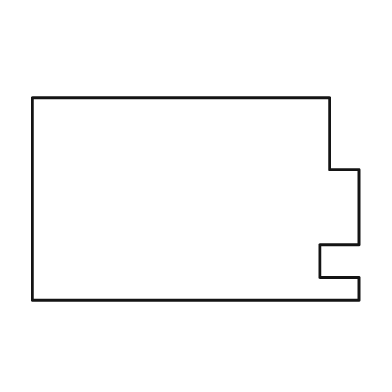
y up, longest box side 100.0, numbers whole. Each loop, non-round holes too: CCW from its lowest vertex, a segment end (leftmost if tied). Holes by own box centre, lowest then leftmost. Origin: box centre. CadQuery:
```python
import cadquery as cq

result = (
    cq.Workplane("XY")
    .moveTo(-50.0, -31.0)
    .lineTo(50.0, -31.0)
    .lineTo(50.0, -24.0)
    .lineTo(38.0, -24.0)
    .lineTo(38.0, -14.0)
    .lineTo(50.0, -14.0)
    .lineTo(50.0, 9.0)
    .lineTo(41.0, 9.0)
    .lineTo(41.0, 31.0)
    .lineTo(-50.0, 31.0)
    .close()
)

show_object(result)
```